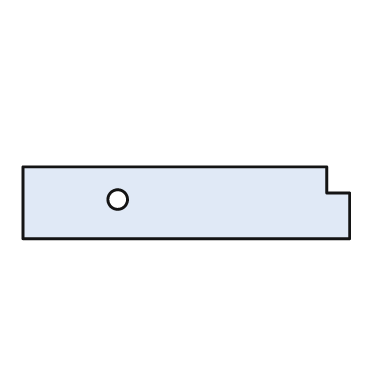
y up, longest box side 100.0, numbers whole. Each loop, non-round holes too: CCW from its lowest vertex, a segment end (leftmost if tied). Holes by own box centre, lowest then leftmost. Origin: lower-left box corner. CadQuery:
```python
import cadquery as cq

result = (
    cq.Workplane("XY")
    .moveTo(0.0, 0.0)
    .lineTo(100.0, 0.0)
    .lineTo(100.0, 14.0)
    .lineTo(93.0, 14.0)
    .lineTo(93.0, 22.0)
    .lineTo(0.0, 22.0)
    .close()
    .moveTo(29.0, 12.0)
    .circle(3.0)
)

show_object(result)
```